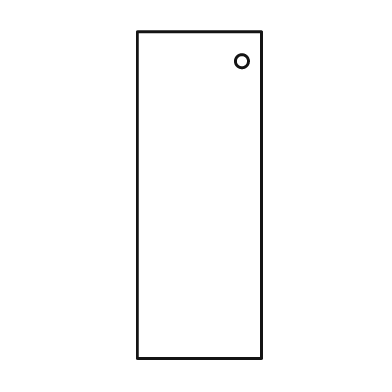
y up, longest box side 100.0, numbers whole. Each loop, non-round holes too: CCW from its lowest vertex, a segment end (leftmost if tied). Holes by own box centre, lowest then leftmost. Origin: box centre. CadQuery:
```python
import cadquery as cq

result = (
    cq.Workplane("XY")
    .moveTo(-19.0, -50.0)
    .lineTo(19.0, -50.0)
    .lineTo(19.0, 50.0)
    .lineTo(-19.0, 50.0)
    .close()
    .moveTo(13.0, 41.0)
    .circle(2.0)
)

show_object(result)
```